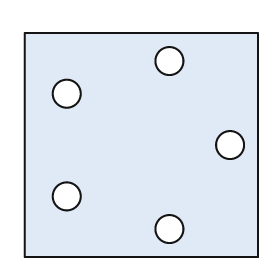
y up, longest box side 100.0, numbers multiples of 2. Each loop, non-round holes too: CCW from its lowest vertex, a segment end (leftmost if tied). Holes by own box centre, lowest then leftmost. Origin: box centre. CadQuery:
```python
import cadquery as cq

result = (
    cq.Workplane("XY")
    .moveTo(-50.0, -48.0)
    .lineTo(50.0, -48.0)
    .lineTo(50.0, 48.0)
    .lineTo(-50.0, 48.0)
    .close()
    .moveTo(12.0, -36.0)
    .circle(6.0)
    .moveTo(-32.0, -22.0)
    .circle(6.0)
    .moveTo(38.0, 0.0)
    .circle(6.0)
    .moveTo(-32.0, 22.0)
    .circle(6.0)
    .moveTo(12.0, 36.0)
    .circle(6.0)
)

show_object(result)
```